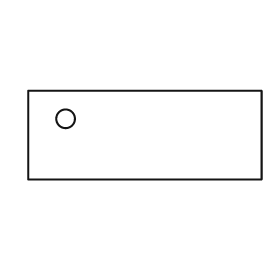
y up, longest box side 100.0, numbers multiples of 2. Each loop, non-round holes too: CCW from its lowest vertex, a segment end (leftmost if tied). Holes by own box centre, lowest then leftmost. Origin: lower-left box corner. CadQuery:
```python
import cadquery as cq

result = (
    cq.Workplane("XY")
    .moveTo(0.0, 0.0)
    .lineTo(100.0, 0.0)
    .lineTo(100.0, 38.0)
    .lineTo(0.0, 38.0)
    .close()
    .moveTo(16.0, 26.0)
    .circle(4.0)
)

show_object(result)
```